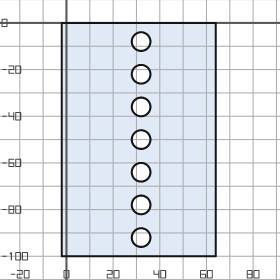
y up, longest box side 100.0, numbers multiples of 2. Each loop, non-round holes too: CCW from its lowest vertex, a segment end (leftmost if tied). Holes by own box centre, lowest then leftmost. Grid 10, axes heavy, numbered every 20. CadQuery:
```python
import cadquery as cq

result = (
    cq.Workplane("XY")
    .moveTo(-2.0, -100.0)
    .lineTo(64.0, -100.0)
    .lineTo(64.0, 0.0)
    .lineTo(-2.0, 0.0)
    .close()
    .moveTo(32.0, -92.0)
    .circle(4.0)
    .moveTo(32.0, -78.0)
    .circle(4.0)
    .moveTo(32.0, -64.0)
    .circle(4.0)
    .moveTo(32.0, -50.0)
    .circle(4.0)
    .moveTo(32.0, -36.0)
    .circle(4.0)
    .moveTo(32.0, -22.0)
    .circle(4.0)
    .moveTo(32.0, -8.0)
    .circle(4.0)
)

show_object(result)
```